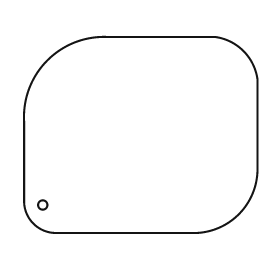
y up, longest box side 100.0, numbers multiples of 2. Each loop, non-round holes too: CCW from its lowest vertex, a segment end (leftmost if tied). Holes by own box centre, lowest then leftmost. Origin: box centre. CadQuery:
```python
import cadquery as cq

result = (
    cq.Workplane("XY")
    .moveTo(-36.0, -42.0)
    .lineTo(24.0, -42.0)
    .threePointArc((42.0, -34.0), (50.0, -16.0))
    .lineTo(50.0, 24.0)
    .threePointArc((44.0, 36.0), (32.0, 42.0))
    .lineTo(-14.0, 42.0)
    .threePointArc((-40.0, 32.0), (-50.0, 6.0))
    .lineTo(-50.0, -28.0)
    .threePointArc((-46.0, -38.0), (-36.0, -42.0))
    .close()
    .moveTo(-42.0, -30.0)
    .circle(2.0)
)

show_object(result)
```